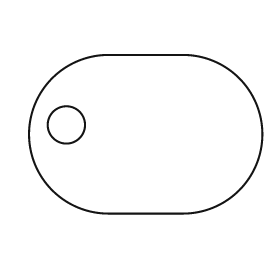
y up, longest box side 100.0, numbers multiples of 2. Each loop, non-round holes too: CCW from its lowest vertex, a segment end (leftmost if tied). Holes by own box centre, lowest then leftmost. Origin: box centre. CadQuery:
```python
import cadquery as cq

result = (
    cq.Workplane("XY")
    .moveTo(-16.0, -34.0)
    .lineTo(16.0, -34.0)
    .threePointArc((50.0, 0.0), (16.0, 34.0))
    .lineTo(-16.0, 34.0)
    .threePointArc((-50.0, 0.0), (-16.0, -34.0))
    .close()
    .moveTo(-34.0, 4.0)
    .circle(8.0)
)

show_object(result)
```